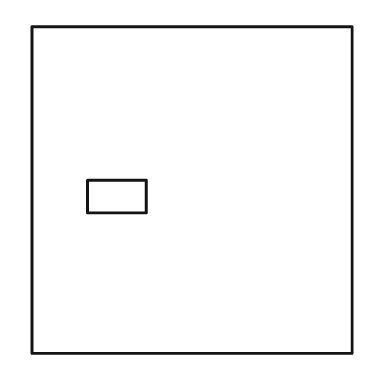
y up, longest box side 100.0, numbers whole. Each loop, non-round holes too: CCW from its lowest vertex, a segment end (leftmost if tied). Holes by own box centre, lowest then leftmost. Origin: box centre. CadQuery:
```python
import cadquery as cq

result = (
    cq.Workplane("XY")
    .moveTo(-49.0, -50.0)
    .lineTo(49.0, -50.0)
    .lineTo(49.0, 50.0)
    .lineTo(-49.0, 50.0)
    .close()
    .moveTo(-32.0, -7.0)
    .lineTo(-14.0, -7.0)
    .lineTo(-14.0, 3.0)
    .lineTo(-32.0, 3.0)
    .close()
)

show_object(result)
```